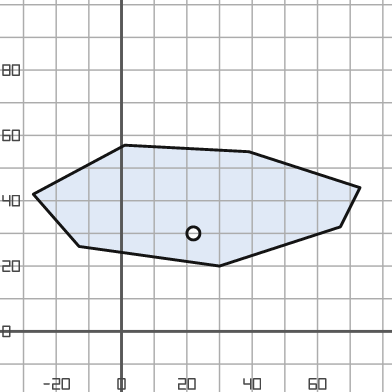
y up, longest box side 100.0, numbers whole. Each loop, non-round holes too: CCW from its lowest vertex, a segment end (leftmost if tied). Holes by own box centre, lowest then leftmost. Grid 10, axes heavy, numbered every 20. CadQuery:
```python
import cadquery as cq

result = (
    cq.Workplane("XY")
    .moveTo(30.0, 20.0)
    .lineTo(67.0, 32.0)
    .lineTo(73.0, 44.0)
    .lineTo(39.0, 55.0)
    .lineTo(1.0, 57.0)
    .lineTo(-27.0, 42.0)
    .lineTo(-13.0, 26.0)
    .close()
    .moveTo(22.0, 30.0)
    .circle(2.0)
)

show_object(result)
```